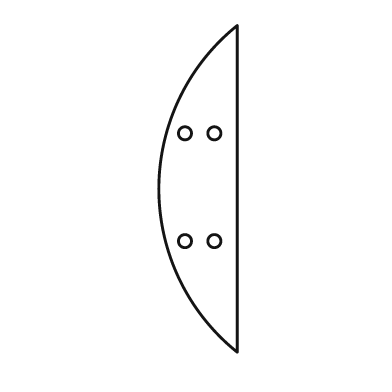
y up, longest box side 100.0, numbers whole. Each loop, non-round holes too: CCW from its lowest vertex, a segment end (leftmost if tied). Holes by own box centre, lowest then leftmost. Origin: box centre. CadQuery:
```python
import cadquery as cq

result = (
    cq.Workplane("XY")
    .moveTo(12.0, -50.0)
    .lineTo(12.0, 50.0)
    .threePointArc((-12.0, 0.0), (12.0, -50.0))
    .close()
    .moveTo(-4.0, -16.0)
    .circle(2.0)
    .moveTo(5.0, -16.0)
    .circle(2.0)
    .moveTo(-4.0, 17.0)
    .circle(2.0)
    .moveTo(5.0, 17.0)
    .circle(2.0)
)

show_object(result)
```